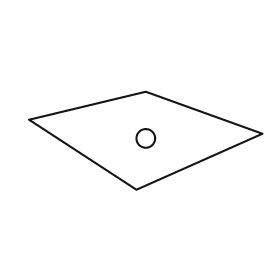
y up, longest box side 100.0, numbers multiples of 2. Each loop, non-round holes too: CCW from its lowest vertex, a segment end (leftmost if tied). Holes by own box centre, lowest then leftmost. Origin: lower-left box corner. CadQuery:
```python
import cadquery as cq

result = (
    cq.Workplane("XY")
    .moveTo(46.0, 0.0)
    .lineTo(100.0, 24.0)
    .lineTo(50.0, 42.0)
    .lineTo(0.0, 30.0)
    .close()
    .moveTo(50.0, 22.0)
    .circle(4.0)
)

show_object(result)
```